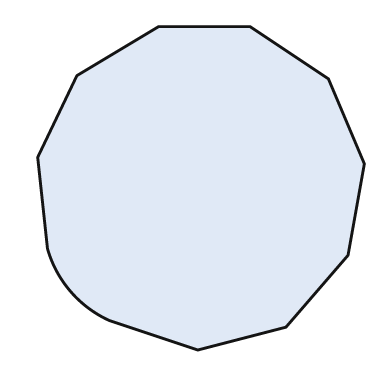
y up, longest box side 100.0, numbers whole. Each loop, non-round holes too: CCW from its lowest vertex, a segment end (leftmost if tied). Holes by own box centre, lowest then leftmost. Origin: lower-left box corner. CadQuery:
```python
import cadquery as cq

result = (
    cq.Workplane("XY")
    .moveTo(49.0, 0.0)
    .lineTo(76.0, 7.0)
    .lineTo(95.0, 29.0)
    .lineTo(100.0, 57.0)
    .lineTo(89.0, 83.0)
    .lineTo(65.0, 99.0)
    .lineTo(37.0, 99.0)
    .lineTo(12.0, 84.0)
    .lineTo(0.0, 59.0)
    .lineTo(3.0, 31.0)
    .threePointArc((10.0, 18.0), (22.0, 9.0))
    .close()
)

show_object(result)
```